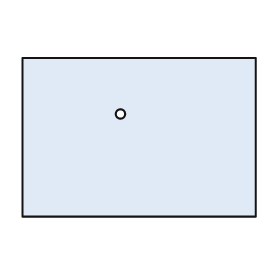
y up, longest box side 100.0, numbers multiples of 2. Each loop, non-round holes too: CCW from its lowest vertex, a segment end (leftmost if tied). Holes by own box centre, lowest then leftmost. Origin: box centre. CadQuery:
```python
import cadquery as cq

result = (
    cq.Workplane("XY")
    .moveTo(-50.0, -34.0)
    .lineTo(50.0, -34.0)
    .lineTo(50.0, 34.0)
    .lineTo(-50.0, 34.0)
    .close()
    .moveTo(-8.0, 10.0)
    .circle(2.0)
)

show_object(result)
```